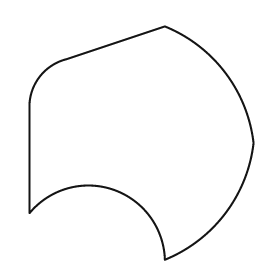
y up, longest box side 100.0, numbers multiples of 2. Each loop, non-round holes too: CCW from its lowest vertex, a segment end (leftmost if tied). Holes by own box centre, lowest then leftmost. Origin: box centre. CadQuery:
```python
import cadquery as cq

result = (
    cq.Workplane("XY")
    .moveTo(10.0, -50.0)
    .threePointArc((36.0, -30.0), (48.0, 0.0))
    .threePointArc((36.0, 30.0), (10.0, 50.0))
    .lineTo(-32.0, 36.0)
    .threePointArc((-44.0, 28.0), (-48.0, 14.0))
    .lineTo(-48.0, -30.0)
    .threePointArc((-12.0, -20.0), (10.0, -50.0))
    .close()
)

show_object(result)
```